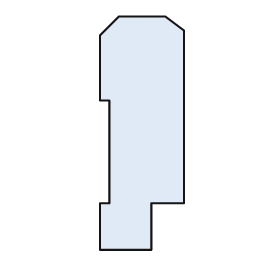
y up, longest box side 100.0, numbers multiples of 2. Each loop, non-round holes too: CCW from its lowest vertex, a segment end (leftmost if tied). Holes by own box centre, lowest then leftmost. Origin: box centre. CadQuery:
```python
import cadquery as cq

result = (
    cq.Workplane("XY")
    .moveTo(-18.0, -50.0)
    .lineTo(4.0, -50.0)
    .lineTo(4.0, -30.0)
    .lineTo(18.0, -30.0)
    .lineTo(18.0, 44.0)
    .lineTo(10.0, 50.0)
    .lineTo(-10.0, 50.0)
    .lineTo(-18.0, 42.0)
    .lineTo(-18.0, 14.0)
    .lineTo(-14.0, 14.0)
    .lineTo(-14.0, -30.0)
    .lineTo(-18.0, -30.0)
    .close()
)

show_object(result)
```